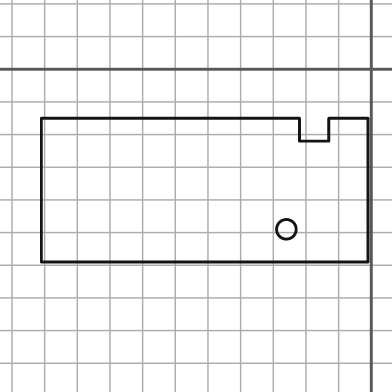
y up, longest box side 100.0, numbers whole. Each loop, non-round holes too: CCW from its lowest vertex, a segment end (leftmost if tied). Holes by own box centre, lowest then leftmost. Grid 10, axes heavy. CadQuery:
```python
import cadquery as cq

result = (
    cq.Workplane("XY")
    .moveTo(-101.0, -59.0)
    .lineTo(-1.0, -59.0)
    .lineTo(-1.0, -15.0)
    .lineTo(-13.0, -15.0)
    .lineTo(-13.0, -22.0)
    .lineTo(-22.0, -22.0)
    .lineTo(-22.0, -15.0)
    .lineTo(-101.0, -15.0)
    .close()
    .moveTo(-26.0, -49.0)
    .circle(3.0)
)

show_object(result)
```